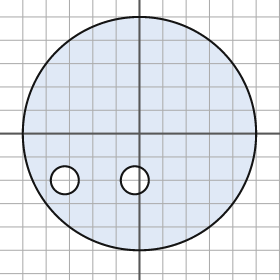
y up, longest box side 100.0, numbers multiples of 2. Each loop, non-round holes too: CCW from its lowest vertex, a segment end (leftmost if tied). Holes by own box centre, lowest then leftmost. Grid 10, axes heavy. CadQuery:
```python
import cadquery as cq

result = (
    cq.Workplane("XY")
    .moveTo(0.0, 0.0)
    .circle(50.0)
    .moveTo(-32.0, -20.0)
    .circle(6.0)
    .moveTo(-2.0, -20.0)
    .circle(6.0)
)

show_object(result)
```